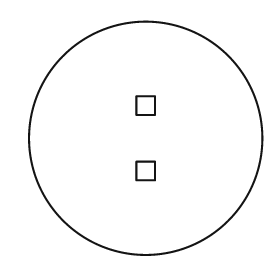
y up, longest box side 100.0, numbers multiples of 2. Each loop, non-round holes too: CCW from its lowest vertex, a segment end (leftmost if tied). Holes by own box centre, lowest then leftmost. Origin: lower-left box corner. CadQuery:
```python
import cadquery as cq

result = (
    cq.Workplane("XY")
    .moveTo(50.0, 50.0)
    .circle(50.0)
    .moveTo(46.0, 32.0)
    .lineTo(54.0, 32.0)
    .lineTo(54.0, 40.0)
    .lineTo(46.0, 40.0)
    .close()
    .moveTo(46.0, 60.0)
    .lineTo(54.0, 60.0)
    .lineTo(54.0, 68.0)
    .lineTo(46.0, 68.0)
    .close()
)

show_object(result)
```